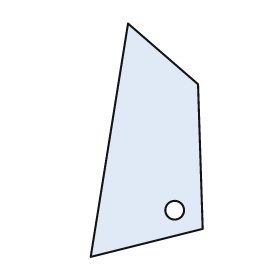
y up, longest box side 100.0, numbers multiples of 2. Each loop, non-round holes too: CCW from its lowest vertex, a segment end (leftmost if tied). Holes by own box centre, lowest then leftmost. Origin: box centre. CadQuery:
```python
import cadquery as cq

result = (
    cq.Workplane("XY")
    .moveTo(-24.0, -50.0)
    .lineTo(24.0, -38.0)
    .lineTo(22.0, 24.0)
    .lineTo(-8.0, 50.0)
    .close()
    .moveTo(12.0, -30.0)
    .circle(4.0)
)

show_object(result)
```